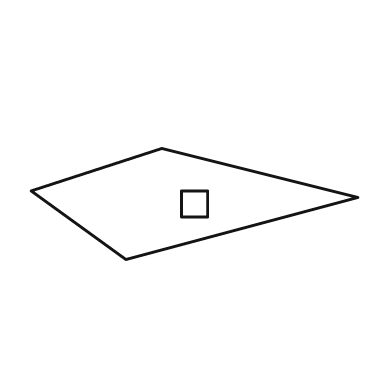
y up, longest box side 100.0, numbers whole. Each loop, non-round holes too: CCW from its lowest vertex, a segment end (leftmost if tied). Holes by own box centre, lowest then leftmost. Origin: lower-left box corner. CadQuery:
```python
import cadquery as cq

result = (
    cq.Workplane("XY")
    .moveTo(29.0, 0.0)
    .lineTo(100.0, 19.0)
    .lineTo(40.0, 34.0)
    .lineTo(0.0, 21.0)
    .close()
    .moveTo(46.0, 13.0)
    .lineTo(54.0, 13.0)
    .lineTo(54.0, 21.0)
    .lineTo(46.0, 21.0)
    .close()
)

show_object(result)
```